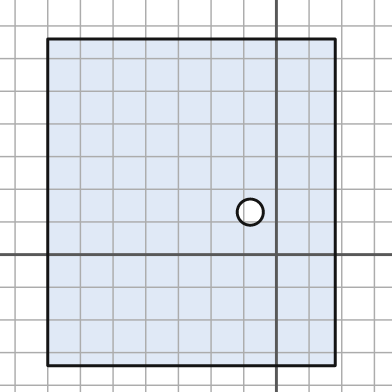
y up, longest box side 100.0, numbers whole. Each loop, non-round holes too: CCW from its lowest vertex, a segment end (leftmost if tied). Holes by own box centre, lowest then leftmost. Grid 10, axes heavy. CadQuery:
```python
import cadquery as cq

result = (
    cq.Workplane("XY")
    .moveTo(-70.0, -34.0)
    .lineTo(18.0, -34.0)
    .lineTo(18.0, 66.0)
    .lineTo(-70.0, 66.0)
    .close()
    .moveTo(-8.0, 13.0)
    .circle(4.0)
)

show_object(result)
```